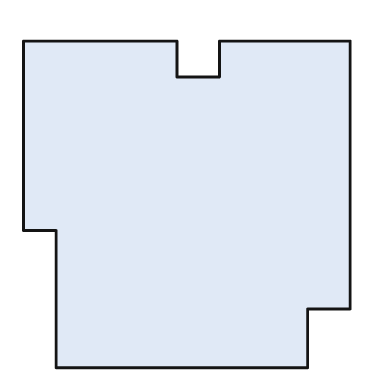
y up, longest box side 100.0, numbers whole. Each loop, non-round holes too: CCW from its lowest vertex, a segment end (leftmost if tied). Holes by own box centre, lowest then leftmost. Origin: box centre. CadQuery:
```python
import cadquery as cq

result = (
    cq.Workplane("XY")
    .moveTo(-40.0, -50.0)
    .lineTo(37.0, -50.0)
    .lineTo(37.0, -32.0)
    .lineTo(50.0, -32.0)
    .lineTo(50.0, 50.0)
    .lineTo(10.0, 50.0)
    .lineTo(10.0, 39.0)
    .lineTo(-3.0, 39.0)
    .lineTo(-3.0, 50.0)
    .lineTo(-50.0, 50.0)
    .lineTo(-50.0, -8.0)
    .lineTo(-40.0, -8.0)
    .close()
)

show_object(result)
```